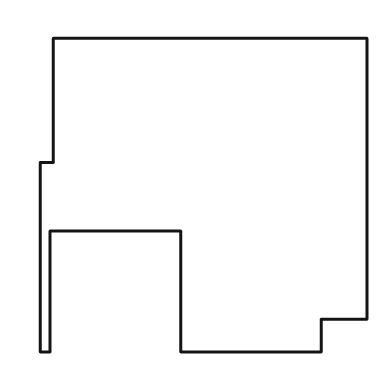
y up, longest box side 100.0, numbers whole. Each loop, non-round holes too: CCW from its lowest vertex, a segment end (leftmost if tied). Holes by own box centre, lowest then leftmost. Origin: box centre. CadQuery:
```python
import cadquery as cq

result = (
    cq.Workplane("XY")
    .moveTo(-50.0, -48.0)
    .lineTo(-47.0, -48.0)
    .lineTo(-47.0, -11.0)
    .lineTo(-7.0, -11.0)
    .lineTo(-7.0, -48.0)
    .lineTo(36.0, -48.0)
    .lineTo(36.0, -38.0)
    .lineTo(50.0, -38.0)
    .lineTo(50.0, 48.0)
    .lineTo(-46.0, 48.0)
    .lineTo(-46.0, 10.0)
    .lineTo(-50.0, 10.0)
    .close()
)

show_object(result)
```